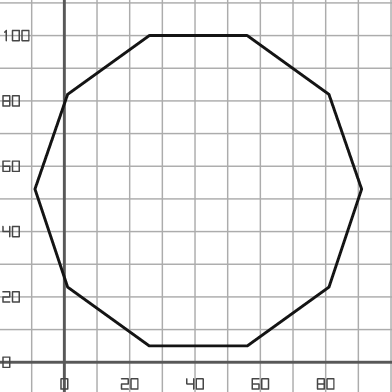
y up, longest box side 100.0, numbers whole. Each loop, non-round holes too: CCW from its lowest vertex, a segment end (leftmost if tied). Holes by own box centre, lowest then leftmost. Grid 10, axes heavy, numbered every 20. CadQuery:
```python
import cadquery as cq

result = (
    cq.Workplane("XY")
    .moveTo(26.0, 5.0)
    .lineTo(56.0, 5.0)
    .lineTo(81.0, 23.0)
    .lineTo(91.0, 53.0)
    .lineTo(81.0, 82.0)
    .lineTo(56.0, 100.0)
    .lineTo(26.0, 100.0)
    .lineTo(1.0, 82.0)
    .lineTo(-9.0, 53.0)
    .lineTo(1.0, 23.0)
    .close()
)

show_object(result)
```